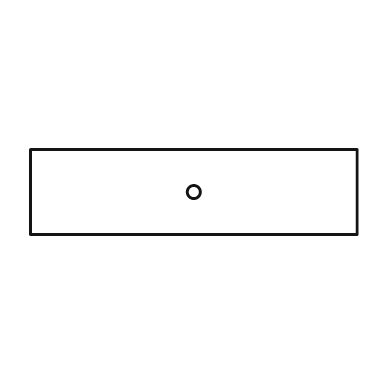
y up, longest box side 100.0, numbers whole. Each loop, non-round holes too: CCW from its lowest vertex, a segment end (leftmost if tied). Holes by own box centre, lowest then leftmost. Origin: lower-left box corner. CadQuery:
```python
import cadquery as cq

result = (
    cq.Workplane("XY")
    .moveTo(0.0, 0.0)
    .lineTo(100.0, 0.0)
    .lineTo(100.0, 26.0)
    .lineTo(0.0, 26.0)
    .close()
    .moveTo(50.0, 13.0)
    .circle(2.0)
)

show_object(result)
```